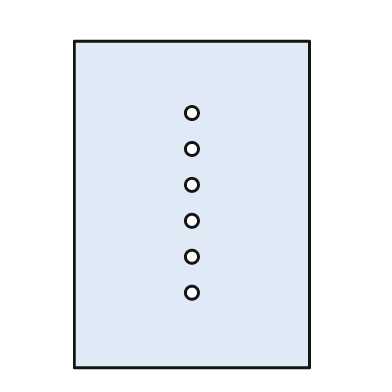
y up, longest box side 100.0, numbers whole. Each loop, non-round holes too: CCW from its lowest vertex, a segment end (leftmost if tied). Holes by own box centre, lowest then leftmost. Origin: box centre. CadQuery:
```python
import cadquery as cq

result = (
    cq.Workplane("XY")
    .moveTo(-36.0, -50.0)
    .lineTo(36.0, -50.0)
    .lineTo(36.0, 50.0)
    .lineTo(-36.0, 50.0)
    .close()
    .moveTo(0.0, -27.0)
    .circle(2.0)
    .moveTo(0.0, -16.0)
    .circle(2.0)
    .moveTo(0.0, -5.0)
    .circle(2.0)
    .moveTo(0.0, 6.0)
    .circle(2.0)
    .moveTo(0.0, 17.0)
    .circle(2.0)
    .moveTo(0.0, 28.0)
    .circle(2.0)
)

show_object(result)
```